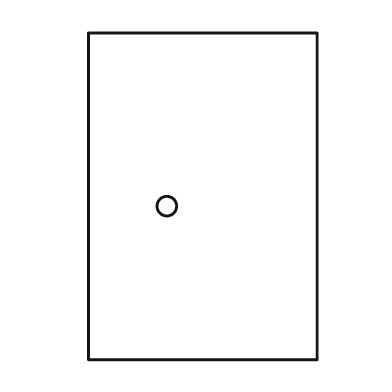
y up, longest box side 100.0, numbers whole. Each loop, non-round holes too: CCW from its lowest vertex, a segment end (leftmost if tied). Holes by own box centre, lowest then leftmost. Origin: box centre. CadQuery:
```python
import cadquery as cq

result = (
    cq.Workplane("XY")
    .moveTo(-35.0, -50.0)
    .lineTo(35.0, -50.0)
    .lineTo(35.0, 50.0)
    .lineTo(-35.0, 50.0)
    .close()
    .moveTo(-11.0, -3.0)
    .circle(3.0)
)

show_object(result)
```